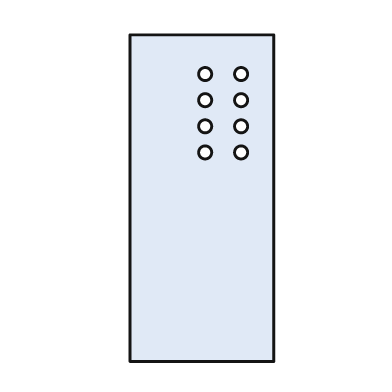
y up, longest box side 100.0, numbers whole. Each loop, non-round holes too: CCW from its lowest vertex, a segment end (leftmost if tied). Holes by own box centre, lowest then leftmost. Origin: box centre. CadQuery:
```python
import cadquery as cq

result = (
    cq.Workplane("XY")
    .moveTo(-22.0, -50.0)
    .lineTo(22.0, -50.0)
    .lineTo(22.0, 50.0)
    .lineTo(-22.0, 50.0)
    .close()
    .moveTo(1.0, 14.0)
    .circle(2.0)
    .moveTo(12.0, 14.0)
    .circle(2.0)
    .moveTo(1.0, 22.0)
    .circle(2.0)
    .moveTo(12.0, 22.0)
    .circle(2.0)
    .moveTo(1.0, 30.0)
    .circle(2.0)
    .moveTo(12.0, 30.0)
    .circle(2.0)
    .moveTo(1.0, 38.0)
    .circle(2.0)
    .moveTo(12.0, 38.0)
    .circle(2.0)
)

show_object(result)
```